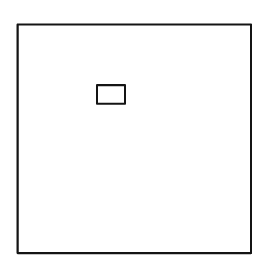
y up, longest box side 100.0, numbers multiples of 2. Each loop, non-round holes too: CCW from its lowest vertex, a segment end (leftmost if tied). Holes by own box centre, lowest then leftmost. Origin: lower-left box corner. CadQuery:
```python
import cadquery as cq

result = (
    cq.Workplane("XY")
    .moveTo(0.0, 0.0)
    .lineTo(100.0, 0.0)
    .lineTo(100.0, 98.0)
    .lineTo(0.0, 98.0)
    .close()
    .moveTo(34.0, 64.0)
    .lineTo(46.0, 64.0)
    .lineTo(46.0, 72.0)
    .lineTo(34.0, 72.0)
    .close()
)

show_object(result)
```